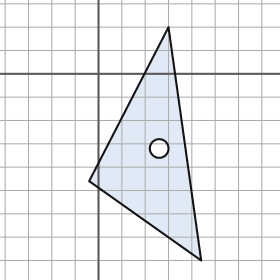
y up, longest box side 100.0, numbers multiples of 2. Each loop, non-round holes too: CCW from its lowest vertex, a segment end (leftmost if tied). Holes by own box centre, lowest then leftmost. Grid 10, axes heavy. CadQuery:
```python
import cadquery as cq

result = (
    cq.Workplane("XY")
    .moveTo(44.0, -80.0)
    .lineTo(30.0, 20.0)
    .lineTo(-4.0, -46.0)
    .close()
    .moveTo(26.0, -32.0)
    .circle(4.0)
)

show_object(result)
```